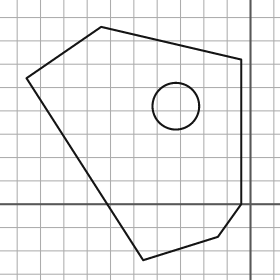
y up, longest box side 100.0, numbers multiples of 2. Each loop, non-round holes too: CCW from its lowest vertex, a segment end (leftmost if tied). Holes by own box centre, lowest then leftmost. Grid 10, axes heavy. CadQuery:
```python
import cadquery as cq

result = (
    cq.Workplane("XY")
    .moveTo(-46.0, -24.0)
    .lineTo(-14.0, -14.0)
    .lineTo(-4.0, 0.0)
    .lineTo(-4.0, 62.0)
    .lineTo(-64.0, 76.0)
    .lineTo(-96.0, 54.0)
    .close()
    .moveTo(-32.0, 42.0)
    .circle(10.0)
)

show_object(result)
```